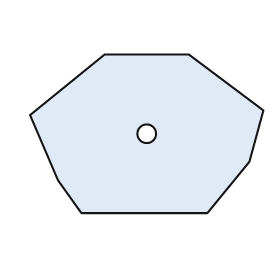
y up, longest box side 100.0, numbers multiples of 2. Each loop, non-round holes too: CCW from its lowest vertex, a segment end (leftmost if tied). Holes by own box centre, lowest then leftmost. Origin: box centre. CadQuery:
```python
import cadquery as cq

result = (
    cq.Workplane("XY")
    .moveTo(-28.0, -34.0)
    .lineTo(26.0, -34.0)
    .lineTo(44.0, -12.0)
    .lineTo(50.0, 10.0)
    .lineTo(18.0, 34.0)
    .lineTo(-18.0, 34.0)
    .lineTo(-50.0, 8.0)
    .lineTo(-38.0, -20.0)
    .close()
    .moveTo(0.0, 0.0)
    .circle(4.0)
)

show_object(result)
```